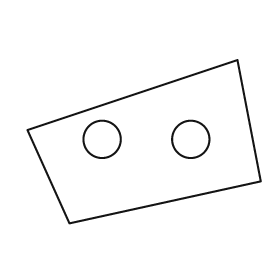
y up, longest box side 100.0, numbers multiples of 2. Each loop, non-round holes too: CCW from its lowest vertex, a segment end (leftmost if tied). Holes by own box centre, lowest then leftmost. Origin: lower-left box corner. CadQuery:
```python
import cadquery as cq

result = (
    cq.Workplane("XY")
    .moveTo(18.0, 0.0)
    .lineTo(100.0, 18.0)
    .lineTo(90.0, 70.0)
    .lineTo(0.0, 40.0)
    .close()
    .moveTo(32.0, 36.0)
    .circle(8.0)
    .moveTo(70.0, 36.0)
    .circle(8.0)
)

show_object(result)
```